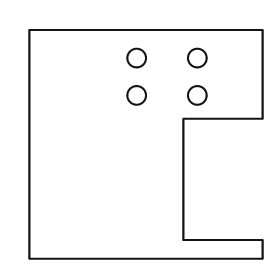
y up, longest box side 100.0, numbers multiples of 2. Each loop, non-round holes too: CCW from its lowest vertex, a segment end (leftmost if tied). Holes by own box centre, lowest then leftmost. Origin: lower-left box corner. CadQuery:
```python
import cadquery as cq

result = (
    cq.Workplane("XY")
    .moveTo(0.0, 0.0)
    .lineTo(100.0, 0.0)
    .lineTo(100.0, 8.0)
    .lineTo(66.0, 8.0)
    .lineTo(66.0, 60.0)
    .lineTo(100.0, 60.0)
    .lineTo(100.0, 98.0)
    .lineTo(0.0, 98.0)
    .close()
    .moveTo(46.0, 70.0)
    .circle(4.0)
    .moveTo(72.0, 70.0)
    .circle(4.0)
    .moveTo(46.0, 86.0)
    .circle(4.0)
    .moveTo(72.0, 86.0)
    .circle(4.0)
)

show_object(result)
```